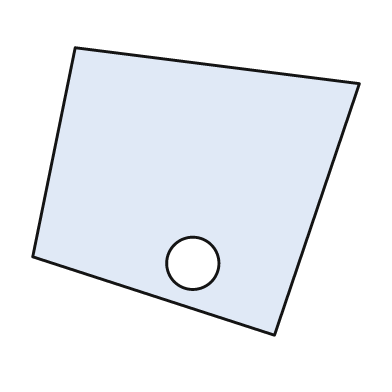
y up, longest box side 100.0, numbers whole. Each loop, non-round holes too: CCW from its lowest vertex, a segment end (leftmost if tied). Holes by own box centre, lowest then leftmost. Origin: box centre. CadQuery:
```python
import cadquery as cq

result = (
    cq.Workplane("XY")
    .moveTo(24.0, -44.0)
    .lineTo(50.0, 33.0)
    .lineTo(-37.0, 44.0)
    .lineTo(-50.0, -20.0)
    .close()
    .moveTo(-1.0, -22.0)
    .circle(8.0)
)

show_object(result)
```